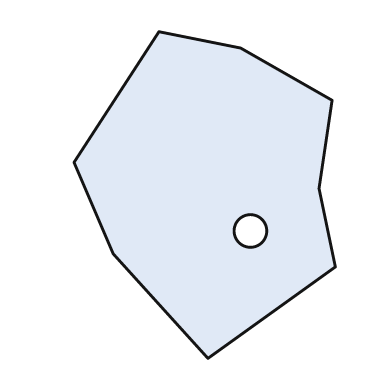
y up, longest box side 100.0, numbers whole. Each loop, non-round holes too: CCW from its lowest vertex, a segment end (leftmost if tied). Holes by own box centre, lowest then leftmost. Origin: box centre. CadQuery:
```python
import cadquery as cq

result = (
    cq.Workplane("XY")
    .moveTo(1.0, -50.0)
    .lineTo(40.0, -22.0)
    .lineTo(35.0, 2.0)
    .lineTo(39.0, 29.0)
    .lineTo(11.0, 45.0)
    .lineTo(-14.0, 50.0)
    .lineTo(-40.0, 10.0)
    .lineTo(-28.0, -18.0)
    .close()
    .moveTo(14.0, -11.0)
    .circle(5.0)
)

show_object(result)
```